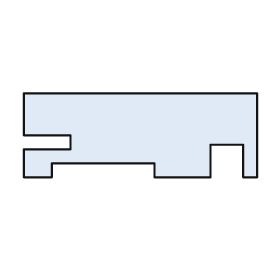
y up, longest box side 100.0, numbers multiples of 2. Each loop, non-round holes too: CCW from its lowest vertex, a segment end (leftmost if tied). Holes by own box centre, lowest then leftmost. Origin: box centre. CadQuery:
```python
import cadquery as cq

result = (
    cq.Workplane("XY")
    .moveTo(-50.0, -18.0)
    .lineTo(-38.0, -18.0)
    .lineTo(-38.0, -12.0)
    .lineTo(6.0, -12.0)
    .lineTo(6.0, -18.0)
    .lineTo(30.0, -18.0)
    .lineTo(30.0, -4.0)
    .lineTo(44.0, -4.0)
    .lineTo(44.0, -18.0)
    .lineTo(50.0, -18.0)
    .lineTo(50.0, 18.0)
    .lineTo(-50.0, 18.0)
    .lineTo(-50.0, 0.0)
    .lineTo(-30.0, 0.0)
    .lineTo(-30.0, -6.0)
    .lineTo(-50.0, -6.0)
    .close()
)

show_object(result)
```